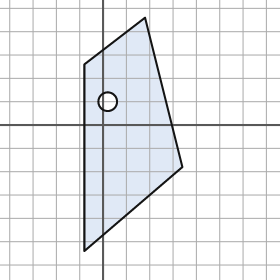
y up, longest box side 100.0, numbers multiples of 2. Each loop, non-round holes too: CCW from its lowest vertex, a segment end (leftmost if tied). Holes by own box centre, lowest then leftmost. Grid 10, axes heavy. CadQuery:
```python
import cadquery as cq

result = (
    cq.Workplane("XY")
    .moveTo(-8.0, -54.0)
    .lineTo(34.0, -18.0)
    .lineTo(18.0, 46.0)
    .lineTo(-8.0, 26.0)
    .close()
    .moveTo(2.0, 10.0)
    .circle(4.0)
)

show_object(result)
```